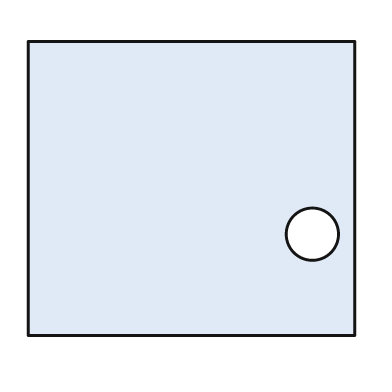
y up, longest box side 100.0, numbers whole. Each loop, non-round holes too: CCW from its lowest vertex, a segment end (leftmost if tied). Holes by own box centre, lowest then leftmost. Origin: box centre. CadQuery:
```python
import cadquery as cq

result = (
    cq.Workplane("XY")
    .moveTo(-50.0, -45.0)
    .lineTo(50.0, -45.0)
    .lineTo(50.0, 45.0)
    .lineTo(-50.0, 45.0)
    .close()
    .moveTo(37.0, -14.0)
    .circle(8.0)
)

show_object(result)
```